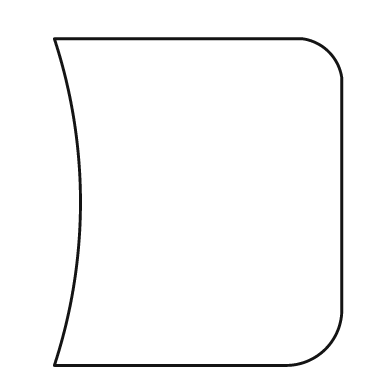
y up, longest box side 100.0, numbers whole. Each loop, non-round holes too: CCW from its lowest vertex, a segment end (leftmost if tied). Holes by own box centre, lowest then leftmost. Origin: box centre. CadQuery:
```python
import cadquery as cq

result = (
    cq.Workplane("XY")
    .moveTo(-44.0, -50.0)
    .lineTo(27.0, -50.0)
    .threePointArc((39.0, -45.0), (44.0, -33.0))
    .lineTo(44.0, 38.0)
    .threePointArc((40.0, 46.0), (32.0, 50.0))
    .lineTo(-44.0, 50.0)
    .threePointArc((-36.0, 0.0), (-44.0, -50.0))
    .close()
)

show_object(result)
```